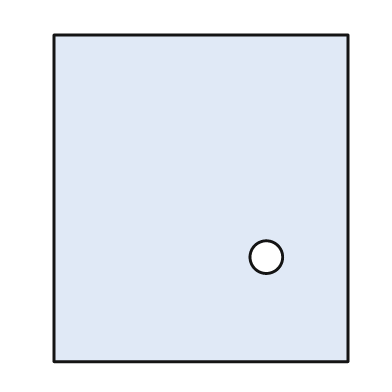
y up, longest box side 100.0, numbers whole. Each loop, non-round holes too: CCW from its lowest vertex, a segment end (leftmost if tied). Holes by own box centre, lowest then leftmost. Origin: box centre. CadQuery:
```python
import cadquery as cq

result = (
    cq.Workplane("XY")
    .moveTo(-45.0, -50.0)
    .lineTo(45.0, -50.0)
    .lineTo(45.0, 50.0)
    .lineTo(-45.0, 50.0)
    .close()
    .moveTo(20.0, -18.0)
    .circle(5.0)
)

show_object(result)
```